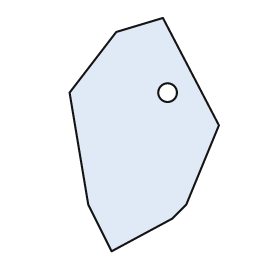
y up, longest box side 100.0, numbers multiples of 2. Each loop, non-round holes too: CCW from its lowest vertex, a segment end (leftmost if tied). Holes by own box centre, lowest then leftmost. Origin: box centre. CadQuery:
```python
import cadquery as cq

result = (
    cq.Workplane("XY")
    .moveTo(-14.0, -50.0)
    .lineTo(12.0, -36.0)
    .lineTo(18.0, -30.0)
    .lineTo(32.0, 4.0)
    .lineTo(8.0, 50.0)
    .lineTo(-12.0, 44.0)
    .lineTo(-32.0, 18.0)
    .lineTo(-24.0, -30.0)
    .close()
    .moveTo(10.0, 18.0)
    .circle(4.0)
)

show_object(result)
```